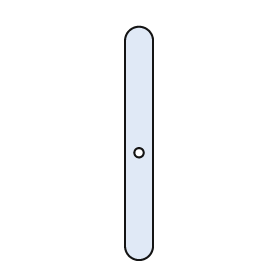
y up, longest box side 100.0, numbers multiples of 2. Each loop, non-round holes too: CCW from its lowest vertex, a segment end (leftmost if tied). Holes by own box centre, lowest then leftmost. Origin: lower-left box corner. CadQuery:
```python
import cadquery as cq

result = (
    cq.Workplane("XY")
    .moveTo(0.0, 6.0)
    .threePointArc((6.0, 0.0), (12.0, 6.0))
    .lineTo(12.0, 94.0)
    .threePointArc((6.0, 100.0), (0.0, 94.0))
    .close()
    .moveTo(6.0, 46.0)
    .circle(2.0)
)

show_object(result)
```